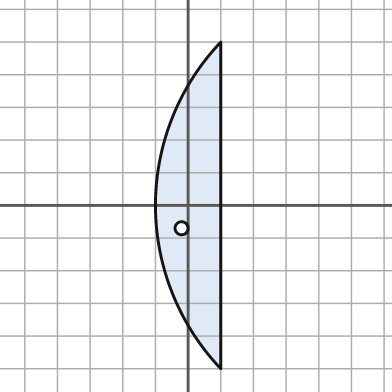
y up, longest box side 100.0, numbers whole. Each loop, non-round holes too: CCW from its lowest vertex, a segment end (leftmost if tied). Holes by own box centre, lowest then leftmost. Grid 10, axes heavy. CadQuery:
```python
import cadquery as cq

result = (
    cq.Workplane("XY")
    .moveTo(10.0, -50.0)
    .lineTo(10.0, 50.0)
    .threePointArc((-10.0, 0.0), (10.0, -50.0))
    .close()
    .moveTo(-2.0, -7.0)
    .circle(2.0)
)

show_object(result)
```